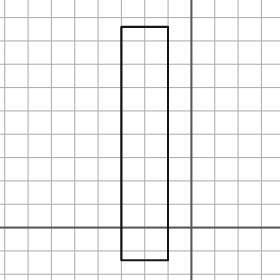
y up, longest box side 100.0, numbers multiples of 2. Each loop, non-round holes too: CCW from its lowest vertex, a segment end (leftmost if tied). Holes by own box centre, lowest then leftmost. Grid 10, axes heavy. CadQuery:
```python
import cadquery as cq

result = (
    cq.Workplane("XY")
    .moveTo(-30.0, -14.0)
    .lineTo(-10.0, -14.0)
    .lineTo(-10.0, 86.0)
    .lineTo(-30.0, 86.0)
    .close()
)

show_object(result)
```